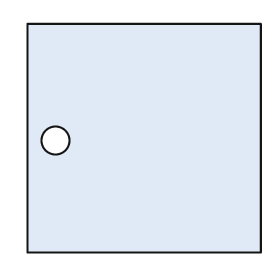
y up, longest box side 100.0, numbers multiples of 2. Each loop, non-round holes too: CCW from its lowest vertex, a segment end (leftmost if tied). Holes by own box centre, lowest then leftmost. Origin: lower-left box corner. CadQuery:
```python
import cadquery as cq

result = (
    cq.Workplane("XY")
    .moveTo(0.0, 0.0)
    .lineTo(100.0, 0.0)
    .lineTo(100.0, 98.0)
    .lineTo(0.0, 98.0)
    .close()
    .moveTo(12.0, 48.0)
    .circle(6.0)
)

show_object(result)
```